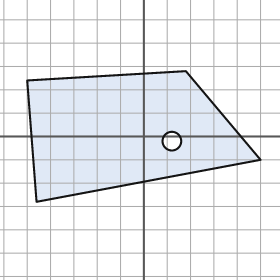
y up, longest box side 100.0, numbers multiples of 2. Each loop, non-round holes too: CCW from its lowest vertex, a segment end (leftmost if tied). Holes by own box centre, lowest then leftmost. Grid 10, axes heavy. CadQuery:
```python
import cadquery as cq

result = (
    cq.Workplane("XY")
    .moveTo(-46.0, -28.0)
    .lineTo(50.0, -10.0)
    .lineTo(18.0, 28.0)
    .lineTo(-50.0, 24.0)
    .close()
    .moveTo(12.0, -2.0)
    .circle(4.0)
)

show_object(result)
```